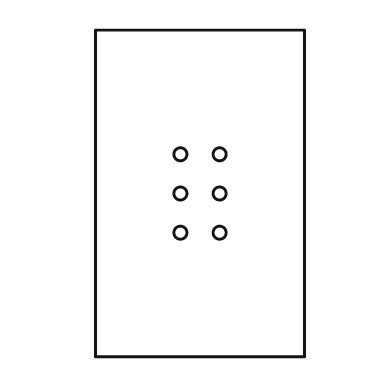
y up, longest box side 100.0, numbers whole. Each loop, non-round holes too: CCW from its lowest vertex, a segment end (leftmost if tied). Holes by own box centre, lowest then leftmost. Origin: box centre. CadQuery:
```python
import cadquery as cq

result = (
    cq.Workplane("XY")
    .moveTo(-32.0, -50.0)
    .lineTo(32.0, -50.0)
    .lineTo(32.0, 50.0)
    .lineTo(-32.0, 50.0)
    .close()
    .moveTo(-6.0, -12.0)
    .circle(2.0)
    .moveTo(6.0, -12.0)
    .circle(2.0)
    .moveTo(-6.0, 0.0)
    .circle(2.0)
    .moveTo(6.0, 0.0)
    .circle(2.0)
    .moveTo(-6.0, 12.0)
    .circle(2.0)
    .moveTo(6.0, 12.0)
    .circle(2.0)
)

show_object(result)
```